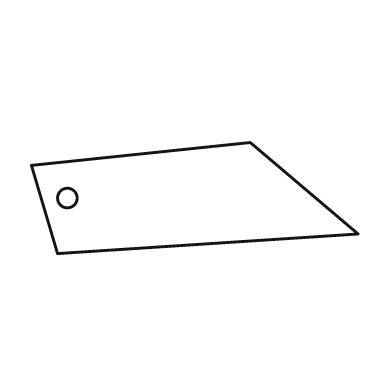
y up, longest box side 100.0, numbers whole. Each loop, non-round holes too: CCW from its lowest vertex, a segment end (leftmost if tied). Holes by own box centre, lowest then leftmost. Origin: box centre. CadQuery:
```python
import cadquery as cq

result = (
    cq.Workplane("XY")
    .moveTo(-42.0, -17.0)
    .lineTo(50.0, -11.0)
    .lineTo(17.0, 17.0)
    .lineTo(-50.0, 10.0)
    .close()
    .moveTo(-39.0, 0.0)
    .circle(3.0)
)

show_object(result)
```